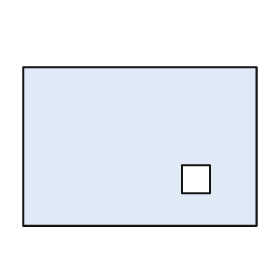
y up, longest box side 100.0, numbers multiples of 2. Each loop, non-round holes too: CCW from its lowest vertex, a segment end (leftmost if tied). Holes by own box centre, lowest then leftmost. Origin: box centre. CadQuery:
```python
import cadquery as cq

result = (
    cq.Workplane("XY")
    .moveTo(-50.0, -34.0)
    .lineTo(50.0, -34.0)
    .lineTo(50.0, 34.0)
    .lineTo(-50.0, 34.0)
    .close()
    .moveTo(18.0, -20.0)
    .lineTo(30.0, -20.0)
    .lineTo(30.0, -8.0)
    .lineTo(18.0, -8.0)
    .close()
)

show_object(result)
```